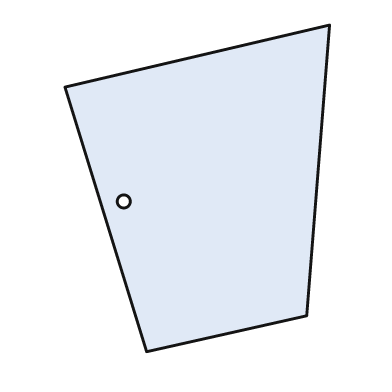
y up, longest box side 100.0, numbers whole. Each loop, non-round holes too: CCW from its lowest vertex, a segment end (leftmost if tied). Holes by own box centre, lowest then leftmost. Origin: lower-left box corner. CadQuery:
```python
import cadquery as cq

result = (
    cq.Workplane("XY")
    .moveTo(25.0, 0.0)
    .lineTo(74.0, 11.0)
    .lineTo(81.0, 100.0)
    .lineTo(0.0, 81.0)
    .close()
    .moveTo(18.0, 46.0)
    .circle(2.0)
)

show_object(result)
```